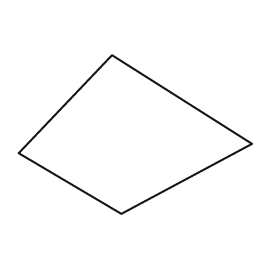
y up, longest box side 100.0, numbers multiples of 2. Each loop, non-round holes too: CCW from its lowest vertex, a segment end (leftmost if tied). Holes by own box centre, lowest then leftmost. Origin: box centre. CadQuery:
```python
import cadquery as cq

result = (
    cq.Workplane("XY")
    .moveTo(-6.0, -34.0)
    .lineTo(50.0, -4.0)
    .lineTo(-10.0, 34.0)
    .lineTo(-50.0, -8.0)
    .close()
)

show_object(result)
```